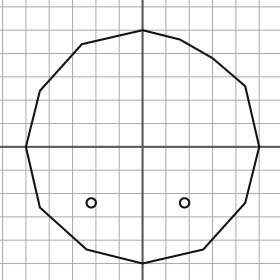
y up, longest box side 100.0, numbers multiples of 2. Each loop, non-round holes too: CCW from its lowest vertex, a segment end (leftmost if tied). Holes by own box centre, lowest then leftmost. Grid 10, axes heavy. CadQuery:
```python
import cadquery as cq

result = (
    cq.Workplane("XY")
    .moveTo(0.0, -50.0)
    .lineTo(26.0, -44.0)
    .lineTo(44.0, -24.0)
    .lineTo(50.0, 0.0)
    .lineTo(44.0, 26.0)
    .lineTo(30.0, 38.0)
    .lineTo(16.0, 46.0)
    .lineTo(0.0, 50.0)
    .lineTo(-26.0, 44.0)
    .lineTo(-44.0, 24.0)
    .lineTo(-50.0, 0.0)
    .lineTo(-44.0, -26.0)
    .lineTo(-24.0, -44.0)
    .close()
    .moveTo(-22.0, -24.0)
    .circle(2.0)
    .moveTo(18.0, -24.0)
    .circle(2.0)
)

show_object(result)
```